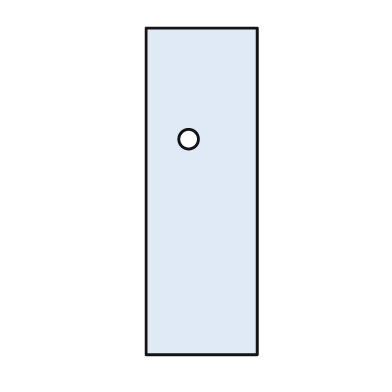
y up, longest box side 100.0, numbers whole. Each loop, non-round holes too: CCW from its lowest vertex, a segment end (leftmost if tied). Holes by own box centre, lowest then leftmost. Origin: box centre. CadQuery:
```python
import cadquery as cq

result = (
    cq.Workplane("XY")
    .moveTo(-17.0, -50.0)
    .lineTo(17.0, -50.0)
    .lineTo(17.0, 50.0)
    .lineTo(-17.0, 50.0)
    .close()
    .moveTo(-4.0, 16.0)
    .circle(3.0)
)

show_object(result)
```